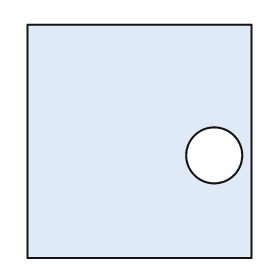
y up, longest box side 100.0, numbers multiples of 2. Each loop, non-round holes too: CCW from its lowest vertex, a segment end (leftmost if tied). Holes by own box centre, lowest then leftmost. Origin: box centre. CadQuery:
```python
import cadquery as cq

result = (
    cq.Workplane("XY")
    .moveTo(-48.0, -50.0)
    .lineTo(48.0, -50.0)
    .lineTo(48.0, 50.0)
    .lineTo(-48.0, 50.0)
    .close()
    .moveTo(32.0, -6.0)
    .circle(12.0)
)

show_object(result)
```